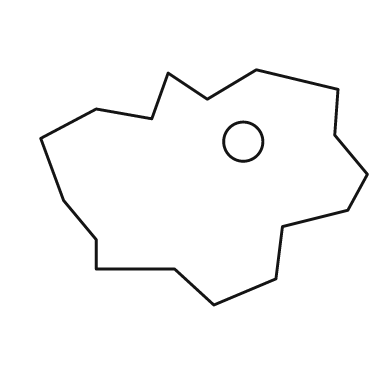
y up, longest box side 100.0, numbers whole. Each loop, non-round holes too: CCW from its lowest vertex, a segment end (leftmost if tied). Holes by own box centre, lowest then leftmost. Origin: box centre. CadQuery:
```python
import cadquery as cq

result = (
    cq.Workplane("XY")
    .moveTo(3.0, -36.0)
    .lineTo(22.0, -28.0)
    .lineTo(24.0, -12.0)
    .lineTo(44.0, -7.0)
    .lineTo(50.0, 4.0)
    .lineTo(40.0, 16.0)
    .lineTo(41.0, 30.0)
    .lineTo(16.0, 36.0)
    .lineTo(1.0, 27.0)
    .lineTo(-11.0, 35.0)
    .lineTo(-16.0, 21.0)
    .lineTo(-33.0, 24.0)
    .lineTo(-50.0, 15.0)
    .lineTo(-43.0, -4.0)
    .lineTo(-33.0, -16.0)
    .lineTo(-33.0, -25.0)
    .lineTo(-9.0, -25.0)
    .close()
    .moveTo(12.0, 14.0)
    .circle(6.0)
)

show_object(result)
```